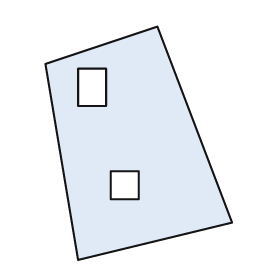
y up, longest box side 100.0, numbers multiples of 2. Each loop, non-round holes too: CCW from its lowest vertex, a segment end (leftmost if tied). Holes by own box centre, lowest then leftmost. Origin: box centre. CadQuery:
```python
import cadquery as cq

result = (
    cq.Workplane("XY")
    .moveTo(-26.0, -50.0)
    .lineTo(40.0, -34.0)
    .lineTo(8.0, 50.0)
    .lineTo(-40.0, 34.0)
    .close()
    .moveTo(-12.0, -24.0)
    .lineTo(0.0, -24.0)
    .lineTo(0.0, -12.0)
    .lineTo(-12.0, -12.0)
    .close()
    .moveTo(-26.0, 16.0)
    .lineTo(-14.0, 16.0)
    .lineTo(-14.0, 32.0)
    .lineTo(-26.0, 32.0)
    .close()
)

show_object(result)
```